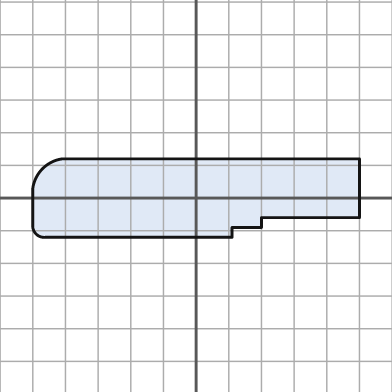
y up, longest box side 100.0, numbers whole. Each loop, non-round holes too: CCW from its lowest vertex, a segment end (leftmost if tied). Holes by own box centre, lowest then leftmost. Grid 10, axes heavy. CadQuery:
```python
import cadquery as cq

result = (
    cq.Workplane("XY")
    .moveTo(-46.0, -12.0)
    .lineTo(11.0, -12.0)
    .lineTo(11.0, -9.0)
    .lineTo(20.0, -9.0)
    .lineTo(20.0, -6.0)
    .lineTo(50.0, -6.0)
    .lineTo(50.0, 12.0)
    .lineTo(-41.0, 12.0)
    .threePointArc((-47.0, 9.0), (-50.0, 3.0))
    .lineTo(-50.0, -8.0)
    .threePointArc((-49.0, -11.0), (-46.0, -12.0))
    .close()
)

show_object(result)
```